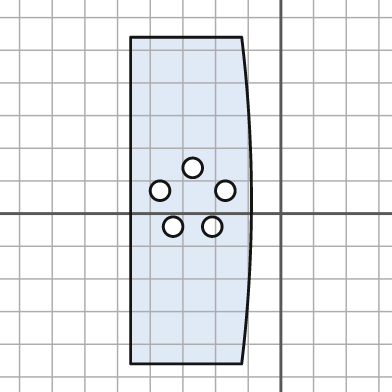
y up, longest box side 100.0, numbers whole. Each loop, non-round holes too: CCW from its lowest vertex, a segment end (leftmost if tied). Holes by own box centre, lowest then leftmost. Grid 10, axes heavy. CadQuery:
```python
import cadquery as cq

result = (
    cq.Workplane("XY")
    .moveTo(-46.0, -46.0)
    .lineTo(-12.0, -46.0)
    .threePointArc((-9.0, 4.0), (-12.0, 54.0))
    .lineTo(-46.0, 54.0)
    .close()
    .moveTo(-33.0, -4.0)
    .circle(3.0)
    .moveTo(-21.0, -4.0)
    .circle(3.0)
    .moveTo(-37.0, 7.0)
    .circle(3.0)
    .moveTo(-17.0, 7.0)
    .circle(3.0)
    .moveTo(-27.0, 14.0)
    .circle(3.0)
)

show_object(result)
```